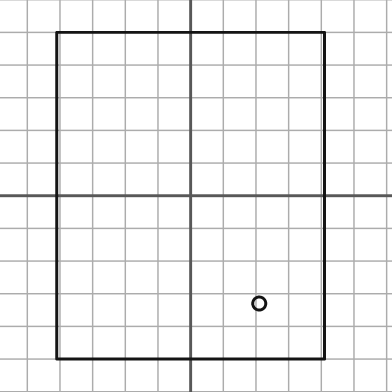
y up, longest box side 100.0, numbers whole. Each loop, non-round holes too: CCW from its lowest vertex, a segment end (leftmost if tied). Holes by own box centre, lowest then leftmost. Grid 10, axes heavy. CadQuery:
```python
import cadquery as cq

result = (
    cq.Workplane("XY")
    .moveTo(-41.0, -50.0)
    .lineTo(41.0, -50.0)
    .lineTo(41.0, 50.0)
    .lineTo(-41.0, 50.0)
    .close()
    .moveTo(21.0, -33.0)
    .circle(2.0)
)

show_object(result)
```